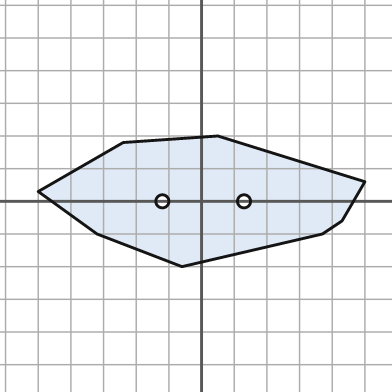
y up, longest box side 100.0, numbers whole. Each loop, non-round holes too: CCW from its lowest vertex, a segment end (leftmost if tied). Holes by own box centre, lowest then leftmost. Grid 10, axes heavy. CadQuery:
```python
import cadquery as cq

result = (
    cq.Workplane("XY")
    .moveTo(-6.0, -20.0)
    .lineTo(37.0, -10.0)
    .lineTo(43.0, -6.0)
    .lineTo(50.0, 6.0)
    .lineTo(5.0, 20.0)
    .lineTo(-24.0, 18.0)
    .lineTo(-50.0, 3.0)
    .lineTo(-32.0, -10.0)
    .close()
    .moveTo(-12.0, 0.0)
    .circle(2.0)
    .moveTo(13.0, 0.0)
    .circle(2.0)
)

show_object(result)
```